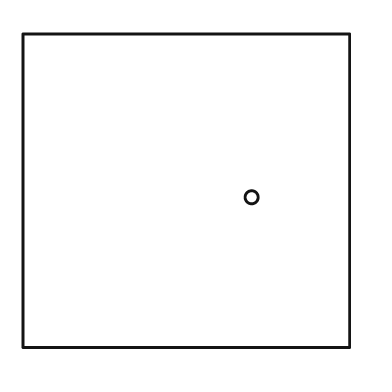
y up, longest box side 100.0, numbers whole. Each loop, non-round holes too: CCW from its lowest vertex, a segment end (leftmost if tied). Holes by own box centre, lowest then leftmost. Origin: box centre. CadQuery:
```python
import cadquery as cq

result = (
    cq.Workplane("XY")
    .moveTo(-50.0, -48.0)
    .lineTo(50.0, -48.0)
    .lineTo(50.0, 48.0)
    .lineTo(-50.0, 48.0)
    .close()
    .moveTo(20.0, -2.0)
    .circle(2.0)
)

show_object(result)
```